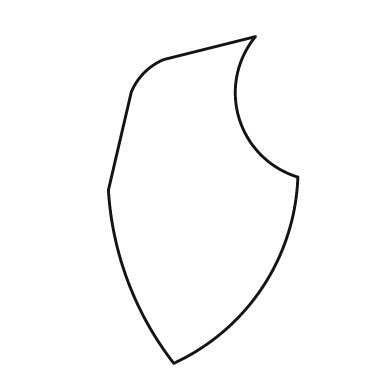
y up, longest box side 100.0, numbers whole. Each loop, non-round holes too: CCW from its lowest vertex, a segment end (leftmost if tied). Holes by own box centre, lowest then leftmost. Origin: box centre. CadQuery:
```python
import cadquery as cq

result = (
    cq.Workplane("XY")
    .moveTo(-9.0, -50.0)
    .threePointArc((18.0, -27.0), (29.0, 7.0))
    .threePointArc((11.0, 25.0), (16.0, 50.0))
    .lineTo(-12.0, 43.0)
    .threePointArc((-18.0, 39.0), (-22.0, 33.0))
    .lineTo(-29.0, 3.0)
    .threePointArc((-23.0, -25.0), (-9.0, -50.0))
    .close()
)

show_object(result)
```